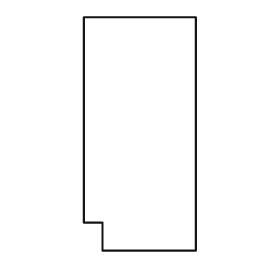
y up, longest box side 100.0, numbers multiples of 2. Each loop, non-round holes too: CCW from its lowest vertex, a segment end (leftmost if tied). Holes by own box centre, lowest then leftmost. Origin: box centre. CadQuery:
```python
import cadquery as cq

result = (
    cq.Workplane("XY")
    .moveTo(-16.0, -50.0)
    .lineTo(24.0, -50.0)
    .lineTo(24.0, 50.0)
    .lineTo(-24.0, 50.0)
    .lineTo(-24.0, -38.0)
    .lineTo(-16.0, -38.0)
    .close()
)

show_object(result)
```